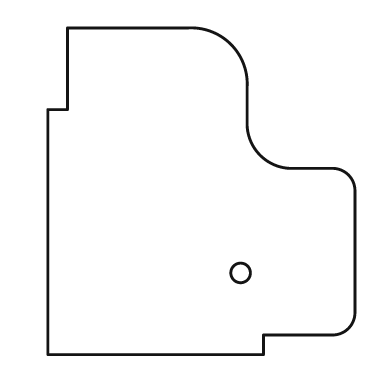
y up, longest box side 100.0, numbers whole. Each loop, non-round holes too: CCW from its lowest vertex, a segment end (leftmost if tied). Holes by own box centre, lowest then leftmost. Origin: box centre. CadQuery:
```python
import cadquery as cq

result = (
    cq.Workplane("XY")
    .moveTo(-47.0, -50.0)
    .lineTo(19.0, -50.0)
    .lineTo(19.0, -44.0)
    .lineTo(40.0, -44.0)
    .threePointArc((45.0, -42.0), (47.0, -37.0))
    .lineTo(47.0, 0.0)
    .threePointArc((45.0, 5.0), (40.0, 7.0))
    .lineTo(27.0, 7.0)
    .threePointArc((18.0, 11.0), (14.0, 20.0))
    .lineTo(14.0, 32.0)
    .threePointArc((9.0, 45.0), (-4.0, 50.0))
    .lineTo(-41.0, 50.0)
    .lineTo(-41.0, 25.0)
    .lineTo(-47.0, 25.0)
    .close()
    .moveTo(12.0, -25.0)
    .circle(3.0)
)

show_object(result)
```